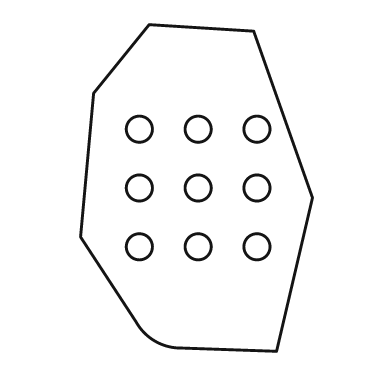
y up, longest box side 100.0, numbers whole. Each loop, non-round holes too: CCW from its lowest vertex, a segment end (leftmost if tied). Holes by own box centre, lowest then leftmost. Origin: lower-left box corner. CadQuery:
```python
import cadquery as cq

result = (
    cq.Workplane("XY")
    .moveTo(60.0, 0.0)
    .lineTo(71.0, 47.0)
    .lineTo(53.0, 98.0)
    .lineTo(21.0, 100.0)
    .lineTo(4.0, 79.0)
    .lineTo(0.0, 35.0)
    .lineTo(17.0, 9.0)
    .threePointArc((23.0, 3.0), (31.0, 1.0))
    .close()
    .moveTo(18.0, 32.0)
    .circle(4.0)
    .moveTo(36.0, 32.0)
    .circle(4.0)
    .moveTo(54.0, 32.0)
    .circle(4.0)
    .moveTo(18.0, 50.0)
    .circle(4.0)
    .moveTo(36.0, 50.0)
    .circle(4.0)
    .moveTo(54.0, 50.0)
    .circle(4.0)
    .moveTo(18.0, 68.0)
    .circle(4.0)
    .moveTo(36.0, 68.0)
    .circle(4.0)
    .moveTo(54.0, 68.0)
    .circle(4.0)
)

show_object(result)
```